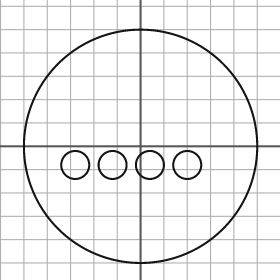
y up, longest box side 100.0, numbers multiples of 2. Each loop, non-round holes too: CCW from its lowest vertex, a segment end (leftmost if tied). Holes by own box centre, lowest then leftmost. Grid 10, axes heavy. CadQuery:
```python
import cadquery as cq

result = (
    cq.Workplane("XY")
    .moveTo(0.0, 0.0)
    .circle(50.0)
    .moveTo(-28.0, -8.0)
    .circle(6.0)
    .moveTo(-12.0, -8.0)
    .circle(6.0)
    .moveTo(4.0, -8.0)
    .circle(6.0)
    .moveTo(20.0, -8.0)
    .circle(6.0)
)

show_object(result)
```